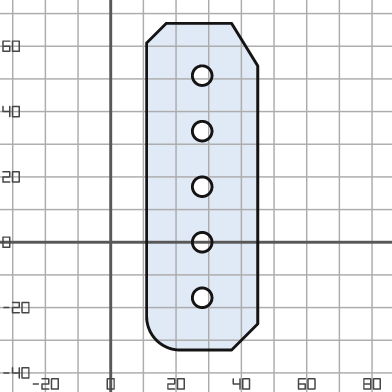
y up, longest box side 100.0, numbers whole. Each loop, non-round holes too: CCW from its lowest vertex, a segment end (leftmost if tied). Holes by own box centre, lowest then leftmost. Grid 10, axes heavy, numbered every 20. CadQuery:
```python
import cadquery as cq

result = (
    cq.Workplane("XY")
    .moveTo(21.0, -33.0)
    .lineTo(37.0, -33.0)
    .lineTo(45.0, -25.0)
    .lineTo(45.0, 54.0)
    .lineTo(37.0, 67.0)
    .lineTo(17.0, 67.0)
    .lineTo(11.0, 61.0)
    .lineTo(11.0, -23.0)
    .threePointArc((14.0, -30.0), (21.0, -33.0))
    .close()
    .moveTo(28.0, -17.0)
    .circle(3.0)
    .moveTo(28.0, 0.0)
    .circle(3.0)
    .moveTo(28.0, 17.0)
    .circle(3.0)
    .moveTo(28.0, 34.0)
    .circle(3.0)
    .moveTo(28.0, 51.0)
    .circle(3.0)
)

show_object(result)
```